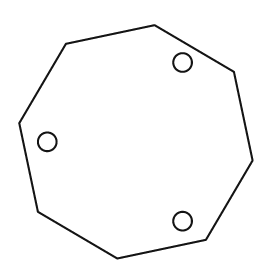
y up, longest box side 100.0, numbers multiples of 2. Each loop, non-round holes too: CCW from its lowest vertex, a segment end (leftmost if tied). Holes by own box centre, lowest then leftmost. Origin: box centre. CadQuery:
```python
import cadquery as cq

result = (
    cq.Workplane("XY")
    .moveTo(-8.0, -50.0)
    .lineTo(30.0, -42.0)
    .lineTo(50.0, -8.0)
    .lineTo(42.0, 30.0)
    .lineTo(8.0, 50.0)
    .lineTo(-30.0, 42.0)
    .lineTo(-50.0, 8.0)
    .lineTo(-42.0, -30.0)
    .close()
    .moveTo(20.0, -34.0)
    .circle(4.0)
    .moveTo(-38.0, 0.0)
    .circle(4.0)
    .moveTo(20.0, 34.0)
    .circle(4.0)
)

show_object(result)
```